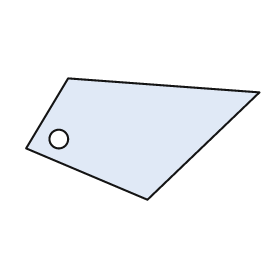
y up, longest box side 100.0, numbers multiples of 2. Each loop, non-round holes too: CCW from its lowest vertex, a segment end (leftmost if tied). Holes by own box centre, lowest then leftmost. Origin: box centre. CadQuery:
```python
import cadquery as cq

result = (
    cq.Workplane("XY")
    .moveTo(2.0, -26.0)
    .lineTo(50.0, 20.0)
    .lineTo(-32.0, 26.0)
    .lineTo(-50.0, -4.0)
    .close()
    .moveTo(-36.0, 0.0)
    .circle(4.0)
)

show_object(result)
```